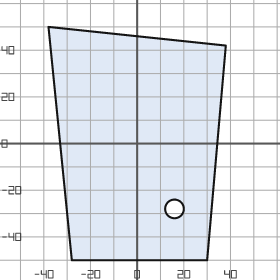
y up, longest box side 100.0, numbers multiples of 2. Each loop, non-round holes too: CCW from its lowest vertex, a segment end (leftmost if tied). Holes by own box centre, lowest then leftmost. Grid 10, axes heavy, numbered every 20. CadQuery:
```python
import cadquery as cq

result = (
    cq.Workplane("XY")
    .moveTo(-28.0, -50.0)
    .lineTo(30.0, -50.0)
    .lineTo(38.0, 42.0)
    .lineTo(-38.0, 50.0)
    .close()
    .moveTo(16.0, -28.0)
    .circle(4.0)
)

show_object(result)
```